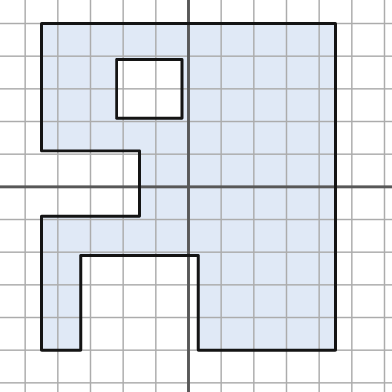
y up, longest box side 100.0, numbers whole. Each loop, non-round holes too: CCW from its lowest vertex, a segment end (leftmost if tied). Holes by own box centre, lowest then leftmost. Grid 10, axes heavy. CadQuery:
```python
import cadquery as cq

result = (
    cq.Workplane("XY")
    .moveTo(-45.0, -50.0)
    .lineTo(-33.0, -50.0)
    .lineTo(-33.0, -21.0)
    .lineTo(3.0, -21.0)
    .lineTo(3.0, -50.0)
    .lineTo(45.0, -50.0)
    .lineTo(45.0, 50.0)
    .lineTo(-45.0, 50.0)
    .lineTo(-45.0, 11.0)
    .lineTo(-15.0, 11.0)
    .lineTo(-15.0, -9.0)
    .lineTo(-45.0, -9.0)
    .close()
    .moveTo(-22.0, 21.0)
    .lineTo(-2.0, 21.0)
    .lineTo(-2.0, 39.0)
    .lineTo(-22.0, 39.0)
    .close()
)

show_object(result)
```